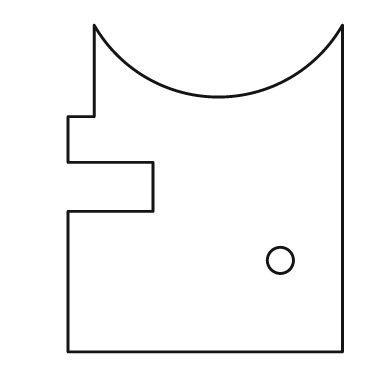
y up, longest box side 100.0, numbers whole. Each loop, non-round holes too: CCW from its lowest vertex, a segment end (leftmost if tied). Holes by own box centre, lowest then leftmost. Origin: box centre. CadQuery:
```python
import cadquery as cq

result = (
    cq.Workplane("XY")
    .moveTo(-42.0, -50.0)
    .lineTo(42.0, -50.0)
    .lineTo(42.0, 50.0)
    .threePointArc((4.0, 28.0), (-34.0, 50.0))
    .lineTo(-34.0, 22.0)
    .lineTo(-42.0, 22.0)
    .lineTo(-42.0, 8.0)
    .lineTo(-16.0, 8.0)
    .lineTo(-16.0, -7.0)
    .lineTo(-42.0, -7.0)
    .close()
    .moveTo(23.0, -22.0)
    .circle(4.0)
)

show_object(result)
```